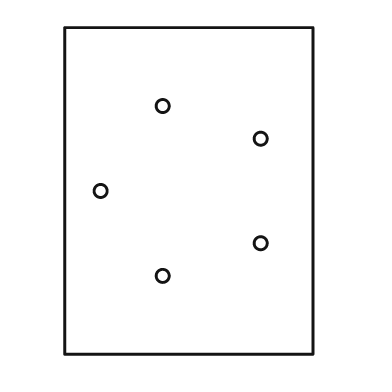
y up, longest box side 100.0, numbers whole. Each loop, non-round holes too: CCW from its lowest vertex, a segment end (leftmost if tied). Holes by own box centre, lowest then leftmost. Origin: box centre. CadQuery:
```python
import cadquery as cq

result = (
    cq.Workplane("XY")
    .moveTo(-38.0, -50.0)
    .lineTo(38.0, -50.0)
    .lineTo(38.0, 50.0)
    .lineTo(-38.0, 50.0)
    .close()
    .moveTo(-8.0, -26.0)
    .circle(2.0)
    .moveTo(22.0, -16.0)
    .circle(2.0)
    .moveTo(-27.0, 0.0)
    .circle(2.0)
    .moveTo(22.0, 16.0)
    .circle(2.0)
    .moveTo(-8.0, 26.0)
    .circle(2.0)
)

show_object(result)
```